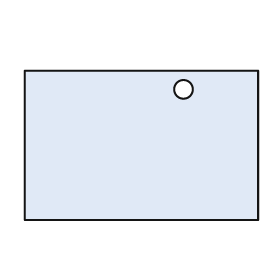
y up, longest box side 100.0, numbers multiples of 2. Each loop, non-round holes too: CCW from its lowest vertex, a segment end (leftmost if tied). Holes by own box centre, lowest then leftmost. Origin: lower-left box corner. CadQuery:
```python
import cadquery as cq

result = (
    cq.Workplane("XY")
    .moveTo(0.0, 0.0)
    .lineTo(100.0, 0.0)
    .lineTo(100.0, 64.0)
    .lineTo(0.0, 64.0)
    .close()
    .moveTo(68.0, 56.0)
    .circle(4.0)
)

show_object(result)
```